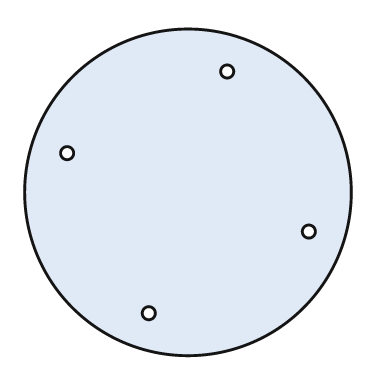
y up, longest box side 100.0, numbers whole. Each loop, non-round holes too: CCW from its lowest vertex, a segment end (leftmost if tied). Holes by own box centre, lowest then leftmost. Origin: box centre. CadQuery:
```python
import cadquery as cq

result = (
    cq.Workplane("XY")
    .moveTo(0.0, 0.0)
    .circle(50.0)
    .moveTo(-12.0, -37.0)
    .circle(2.0)
    .moveTo(37.0, -12.0)
    .circle(2.0)
    .moveTo(-37.0, 12.0)
    .circle(2.0)
    .moveTo(12.0, 37.0)
    .circle(2.0)
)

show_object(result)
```